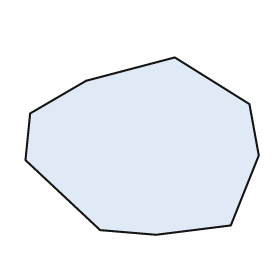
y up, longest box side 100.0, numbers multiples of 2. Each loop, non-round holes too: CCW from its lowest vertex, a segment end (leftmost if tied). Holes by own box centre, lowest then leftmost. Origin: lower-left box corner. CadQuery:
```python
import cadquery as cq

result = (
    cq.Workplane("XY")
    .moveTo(56.0, 0.0)
    .lineTo(88.0, 4.0)
    .lineTo(100.0, 34.0)
    .lineTo(96.0, 56.0)
    .lineTo(64.0, 76.0)
    .lineTo(26.0, 66.0)
    .lineTo(2.0, 52.0)
    .lineTo(0.0, 32.0)
    .lineTo(32.0, 2.0)
    .close()
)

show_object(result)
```